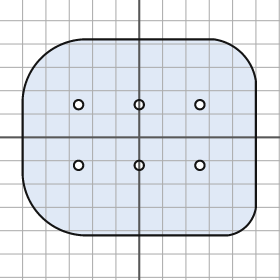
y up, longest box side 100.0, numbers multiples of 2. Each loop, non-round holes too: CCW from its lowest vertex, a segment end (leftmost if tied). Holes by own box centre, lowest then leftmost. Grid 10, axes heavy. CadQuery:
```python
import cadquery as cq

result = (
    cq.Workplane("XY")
    .moveTo(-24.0, -42.0)
    .lineTo(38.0, -42.0)
    .threePointArc((46.0, -38.0), (50.0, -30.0))
    .lineTo(50.0, 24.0)
    .threePointArc((44.0, 36.0), (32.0, 42.0))
    .lineTo(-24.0, 42.0)
    .threePointArc((-42.0, 34.0), (-50.0, 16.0))
    .lineTo(-50.0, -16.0)
    .threePointArc((-42.0, -34.0), (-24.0, -42.0))
    .close()
    .moveTo(-26.0, -12.0)
    .circle(2.0)
    .moveTo(0.0, -12.0)
    .circle(2.0)
    .moveTo(26.0, -12.0)
    .circle(2.0)
    .moveTo(-26.0, 14.0)
    .circle(2.0)
    .moveTo(0.0, 14.0)
    .circle(2.0)
    .moveTo(26.0, 14.0)
    .circle(2.0)
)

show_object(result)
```